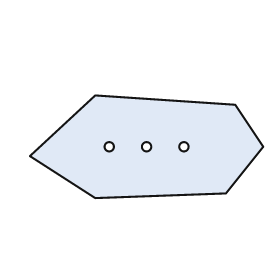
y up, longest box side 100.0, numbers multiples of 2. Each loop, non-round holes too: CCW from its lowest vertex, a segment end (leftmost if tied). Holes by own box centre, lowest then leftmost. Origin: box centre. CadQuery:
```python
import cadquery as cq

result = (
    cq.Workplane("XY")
    .moveTo(-22.0, -22.0)
    .lineTo(34.0, -20.0)
    .lineTo(50.0, 0.0)
    .lineTo(38.0, 18.0)
    .lineTo(-22.0, 22.0)
    .lineTo(-50.0, -4.0)
    .close()
    .moveTo(-16.0, 0.0)
    .circle(2.0)
    .moveTo(0.0, 0.0)
    .circle(2.0)
    .moveTo(16.0, 0.0)
    .circle(2.0)
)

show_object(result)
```